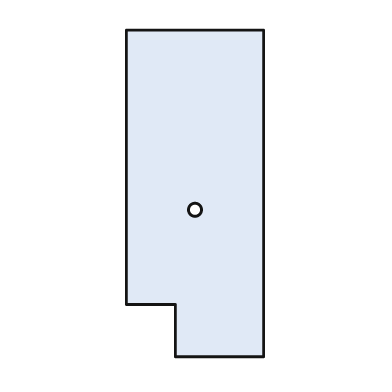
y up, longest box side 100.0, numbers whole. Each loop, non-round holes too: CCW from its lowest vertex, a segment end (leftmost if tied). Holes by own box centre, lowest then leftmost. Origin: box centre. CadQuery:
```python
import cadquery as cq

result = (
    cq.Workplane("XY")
    .moveTo(-6.0, -50.0)
    .lineTo(21.0, -50.0)
    .lineTo(21.0, 50.0)
    .lineTo(-21.0, 50.0)
    .lineTo(-21.0, -34.0)
    .lineTo(-6.0, -34.0)
    .close()
    .moveTo(0.0, -5.0)
    .circle(2.0)
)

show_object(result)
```